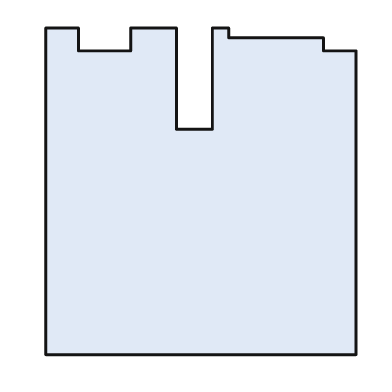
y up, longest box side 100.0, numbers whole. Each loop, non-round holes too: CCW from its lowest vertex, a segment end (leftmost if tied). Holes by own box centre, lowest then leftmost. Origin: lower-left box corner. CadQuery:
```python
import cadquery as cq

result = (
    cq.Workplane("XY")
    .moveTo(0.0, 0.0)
    .lineTo(95.0, 0.0)
    .lineTo(95.0, 93.0)
    .lineTo(85.0, 93.0)
    .lineTo(85.0, 97.0)
    .lineTo(56.0, 97.0)
    .lineTo(56.0, 100.0)
    .lineTo(51.0, 100.0)
    .lineTo(51.0, 69.0)
    .lineTo(40.0, 69.0)
    .lineTo(40.0, 100.0)
    .lineTo(26.0, 100.0)
    .lineTo(26.0, 93.0)
    .lineTo(10.0, 93.0)
    .lineTo(10.0, 100.0)
    .lineTo(0.0, 100.0)
    .close()
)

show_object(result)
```